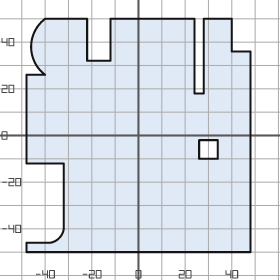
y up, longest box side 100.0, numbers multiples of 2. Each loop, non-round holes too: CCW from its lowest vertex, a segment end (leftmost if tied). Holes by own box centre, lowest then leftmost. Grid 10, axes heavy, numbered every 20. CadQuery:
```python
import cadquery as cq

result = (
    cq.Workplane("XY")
    .moveTo(-48.0, -50.0)
    .lineTo(48.0, -50.0)
    .lineTo(48.0, 36.0)
    .lineTo(40.0, 36.0)
    .lineTo(40.0, 50.0)
    .lineTo(28.0, 50.0)
    .lineTo(28.0, 18.0)
    .lineTo(24.0, 18.0)
    .lineTo(24.0, 50.0)
    .lineTo(-12.0, 50.0)
    .lineTo(-12.0, 32.0)
    .lineTo(-22.0, 32.0)
    .lineTo(-22.0, 50.0)
    .lineTo(-40.0, 50.0)
    .threePointArc((-46.0, 38.0), (-40.0, 26.0))
    .lineTo(-48.0, 26.0)
    .lineTo(-48.0, -12.0)
    .lineTo(-32.0, -12.0)
    .lineTo(-32.0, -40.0)
    .threePointArc((-34.0, -44.0), (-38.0, -46.0))
    .lineTo(-48.0, -46.0)
    .close()
    .moveTo(26.0, -10.0)
    .lineTo(34.0, -10.0)
    .lineTo(34.0, -2.0)
    .lineTo(26.0, -2.0)
    .close()
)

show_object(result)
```